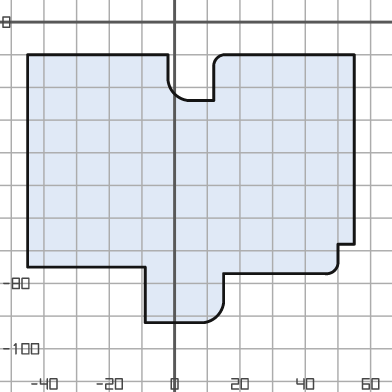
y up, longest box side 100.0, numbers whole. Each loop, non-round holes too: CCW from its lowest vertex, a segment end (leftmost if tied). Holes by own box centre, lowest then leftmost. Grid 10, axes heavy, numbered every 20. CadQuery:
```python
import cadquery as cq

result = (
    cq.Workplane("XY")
    .moveTo(-9.0, -92.0)
    .lineTo(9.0, -92.0)
    .threePointArc((13.0, -90.0), (15.0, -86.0))
    .lineTo(15.0, -77.0)
    .lineTo(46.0, -77.0)
    .threePointArc((49.0, -76.0), (50.0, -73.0))
    .lineTo(50.0, -68.0)
    .lineTo(55.0, -68.0)
    .lineTo(55.0, -10.0)
    .lineTo(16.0, -10.0)
    .threePointArc((13.0, -11.0), (12.0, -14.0))
    .lineTo(12.0, -24.0)
    .lineTo(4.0, -24.0)
    .threePointArc((0.0, -22.0), (-2.0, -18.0))
    .lineTo(-2.0, -10.0)
    .lineTo(-45.0, -10.0)
    .lineTo(-45.0, -75.0)
    .lineTo(-9.0, -75.0)
    .close()
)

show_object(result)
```